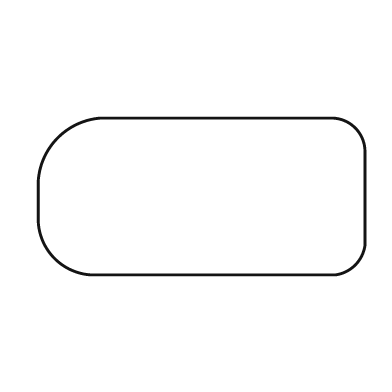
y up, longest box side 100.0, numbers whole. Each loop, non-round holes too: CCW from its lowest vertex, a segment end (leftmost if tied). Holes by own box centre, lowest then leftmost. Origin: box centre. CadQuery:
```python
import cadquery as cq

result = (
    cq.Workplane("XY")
    .moveTo(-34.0, -24.0)
    .lineTo(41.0, -24.0)
    .threePointArc((47.0, -21.0), (50.0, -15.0))
    .lineTo(50.0, 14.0)
    .threePointArc((47.0, 21.0), (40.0, 24.0))
    .lineTo(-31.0, 24.0)
    .threePointArc((-44.0, 18.0), (-50.0, 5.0))
    .lineTo(-50.0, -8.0)
    .threePointArc((-45.0, -19.0), (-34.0, -24.0))
    .close()
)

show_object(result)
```